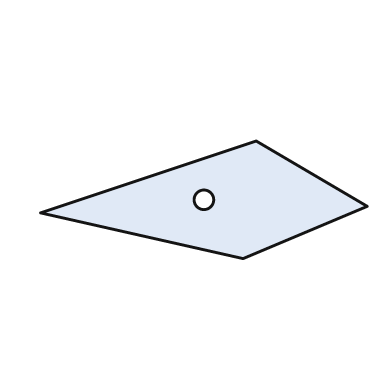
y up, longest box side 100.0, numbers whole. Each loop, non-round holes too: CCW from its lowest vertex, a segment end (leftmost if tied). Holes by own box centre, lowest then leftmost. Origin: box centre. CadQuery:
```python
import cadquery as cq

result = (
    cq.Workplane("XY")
    .moveTo(12.0, -18.0)
    .lineTo(50.0, -2.0)
    .lineTo(16.0, 18.0)
    .lineTo(-50.0, -4.0)
    .close()
    .moveTo(0.0, 0.0)
    .circle(3.0)
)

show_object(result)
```